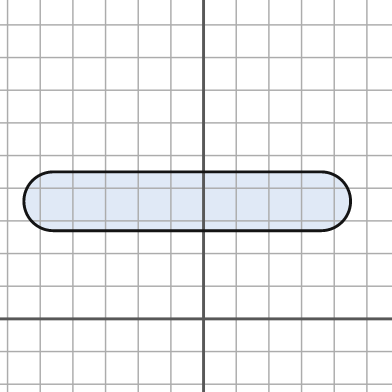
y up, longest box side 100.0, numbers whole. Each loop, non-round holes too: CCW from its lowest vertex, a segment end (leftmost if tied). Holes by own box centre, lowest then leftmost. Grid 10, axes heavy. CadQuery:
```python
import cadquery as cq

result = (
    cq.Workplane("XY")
    .moveTo(-46.0, 27.0)
    .lineTo(36.0, 27.0)
    .threePointArc((45.0, 36.0), (36.0, 45.0))
    .lineTo(-46.0, 45.0)
    .threePointArc((-55.0, 36.0), (-46.0, 27.0))
    .close()
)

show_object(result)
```